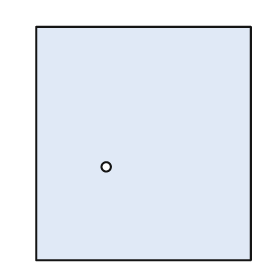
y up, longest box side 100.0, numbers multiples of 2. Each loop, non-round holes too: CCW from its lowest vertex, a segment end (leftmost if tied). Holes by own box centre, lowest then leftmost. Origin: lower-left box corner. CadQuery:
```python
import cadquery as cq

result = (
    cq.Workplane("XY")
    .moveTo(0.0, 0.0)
    .lineTo(92.0, 0.0)
    .lineTo(92.0, 100.0)
    .lineTo(0.0, 100.0)
    .close()
    .moveTo(30.0, 40.0)
    .circle(2.0)
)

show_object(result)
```